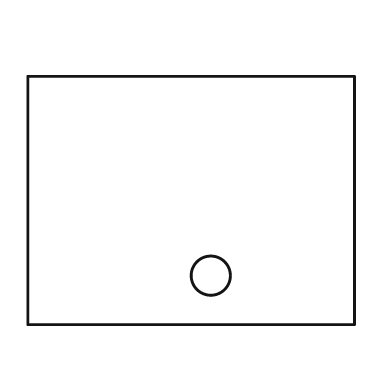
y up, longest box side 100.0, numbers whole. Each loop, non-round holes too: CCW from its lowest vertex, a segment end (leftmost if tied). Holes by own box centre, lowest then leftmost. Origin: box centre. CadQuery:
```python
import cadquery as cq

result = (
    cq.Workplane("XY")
    .moveTo(-50.0, -38.0)
    .lineTo(50.0, -38.0)
    .lineTo(50.0, 38.0)
    .lineTo(-50.0, 38.0)
    .close()
    .moveTo(6.0, -23.0)
    .circle(6.0)
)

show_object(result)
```